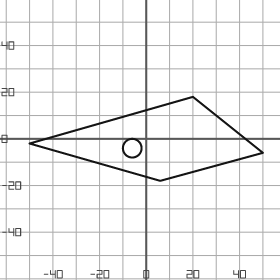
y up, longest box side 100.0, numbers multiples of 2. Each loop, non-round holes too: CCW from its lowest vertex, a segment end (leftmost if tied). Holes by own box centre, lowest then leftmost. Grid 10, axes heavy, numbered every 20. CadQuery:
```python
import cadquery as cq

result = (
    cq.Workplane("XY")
    .moveTo(6.0, -18.0)
    .lineTo(50.0, -6.0)
    .lineTo(20.0, 18.0)
    .lineTo(-50.0, -2.0)
    .close()
    .moveTo(-6.0, -4.0)
    .circle(4.0)
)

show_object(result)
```